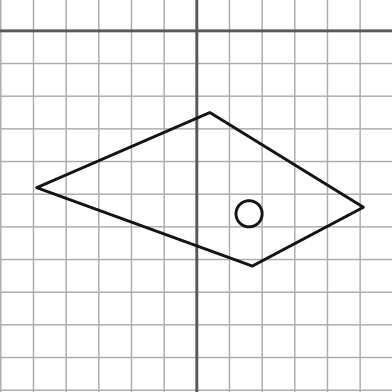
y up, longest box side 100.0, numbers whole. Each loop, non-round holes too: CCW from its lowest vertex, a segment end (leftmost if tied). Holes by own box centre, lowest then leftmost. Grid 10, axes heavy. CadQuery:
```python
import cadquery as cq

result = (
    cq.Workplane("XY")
    .moveTo(17.0, -72.0)
    .lineTo(51.0, -54.0)
    .lineTo(4.0, -25.0)
    .lineTo(-49.0, -48.0)
    .close()
    .moveTo(16.0, -56.0)
    .circle(4.0)
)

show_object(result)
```